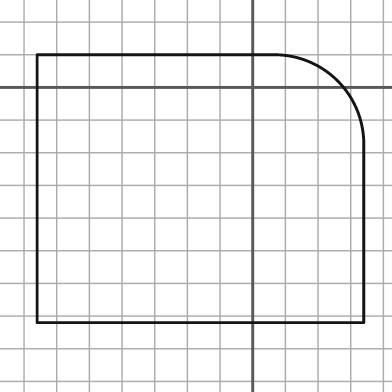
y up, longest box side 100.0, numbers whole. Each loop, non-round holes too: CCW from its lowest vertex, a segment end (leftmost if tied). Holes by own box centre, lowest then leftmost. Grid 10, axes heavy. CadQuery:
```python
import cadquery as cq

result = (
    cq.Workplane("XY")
    .moveTo(-66.0, -72.0)
    .lineTo(34.0, -72.0)
    .lineTo(34.0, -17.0)
    .threePointArc((26.0, 2.0), (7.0, 10.0))
    .lineTo(-66.0, 10.0)
    .close()
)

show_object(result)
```